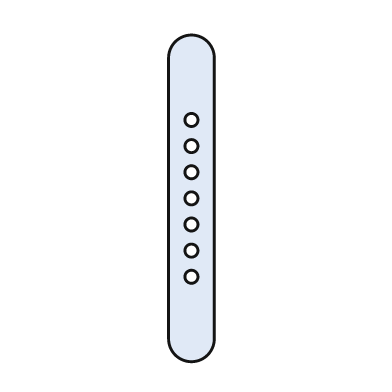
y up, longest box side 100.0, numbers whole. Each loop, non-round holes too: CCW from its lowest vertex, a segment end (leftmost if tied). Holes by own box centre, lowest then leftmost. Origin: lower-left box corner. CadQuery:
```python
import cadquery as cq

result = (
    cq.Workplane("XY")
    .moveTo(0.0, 7.0)
    .threePointArc((7.0, 0.0), (14.0, 7.0))
    .lineTo(14.0, 93.0)
    .threePointArc((7.0, 100.0), (0.0, 93.0))
    .close()
    .moveTo(7.0, 26.0)
    .circle(2.0)
    .moveTo(7.0, 34.0)
    .circle(2.0)
    .moveTo(7.0, 42.0)
    .circle(2.0)
    .moveTo(7.0, 50.0)
    .circle(2.0)
    .moveTo(7.0, 58.0)
    .circle(2.0)
    .moveTo(7.0, 66.0)
    .circle(2.0)
    .moveTo(7.0, 74.0)
    .circle(2.0)
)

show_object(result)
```